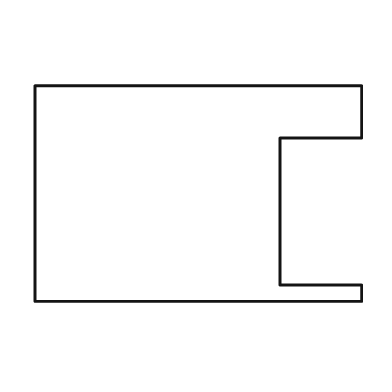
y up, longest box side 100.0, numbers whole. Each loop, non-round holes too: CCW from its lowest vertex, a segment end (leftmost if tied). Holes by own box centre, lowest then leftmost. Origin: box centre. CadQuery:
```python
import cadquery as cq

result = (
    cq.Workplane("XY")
    .moveTo(-50.0, -33.0)
    .lineTo(50.0, -33.0)
    .lineTo(50.0, -28.0)
    .lineTo(25.0, -28.0)
    .lineTo(25.0, 17.0)
    .lineTo(50.0, 17.0)
    .lineTo(50.0, 33.0)
    .lineTo(-50.0, 33.0)
    .close()
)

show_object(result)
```